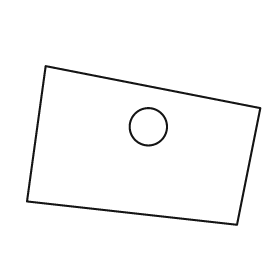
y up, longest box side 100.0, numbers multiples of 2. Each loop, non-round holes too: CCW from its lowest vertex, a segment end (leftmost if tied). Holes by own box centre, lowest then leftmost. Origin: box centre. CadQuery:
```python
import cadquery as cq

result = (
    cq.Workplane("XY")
    .moveTo(40.0, -34.0)
    .lineTo(50.0, 16.0)
    .lineTo(-42.0, 34.0)
    .lineTo(-50.0, -24.0)
    .close()
    .moveTo(2.0, 8.0)
    .circle(8.0)
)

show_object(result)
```